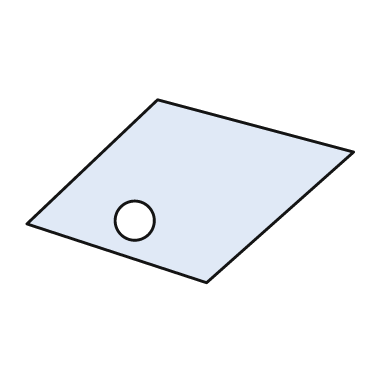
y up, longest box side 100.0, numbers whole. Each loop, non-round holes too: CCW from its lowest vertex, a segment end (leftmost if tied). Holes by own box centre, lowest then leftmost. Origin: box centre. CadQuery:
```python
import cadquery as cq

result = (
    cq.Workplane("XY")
    .moveTo(5.0, -28.0)
    .lineTo(50.0, 12.0)
    .lineTo(-10.0, 28.0)
    .lineTo(-50.0, -10.0)
    .close()
    .moveTo(-17.0, -9.0)
    .circle(6.0)
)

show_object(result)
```